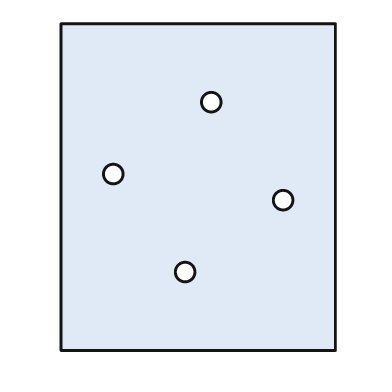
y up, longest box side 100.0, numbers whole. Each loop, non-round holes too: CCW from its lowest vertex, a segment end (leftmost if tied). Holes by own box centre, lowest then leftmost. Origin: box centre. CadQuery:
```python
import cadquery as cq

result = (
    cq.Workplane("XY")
    .moveTo(-42.0, -50.0)
    .lineTo(42.0, -50.0)
    .lineTo(42.0, 50.0)
    .lineTo(-42.0, 50.0)
    .close()
    .moveTo(-4.0, -26.0)
    .circle(3.0)
    .moveTo(26.0, -4.0)
    .circle(3.0)
    .moveTo(-26.0, 4.0)
    .circle(3.0)
    .moveTo(4.0, 26.0)
    .circle(3.0)
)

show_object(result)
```